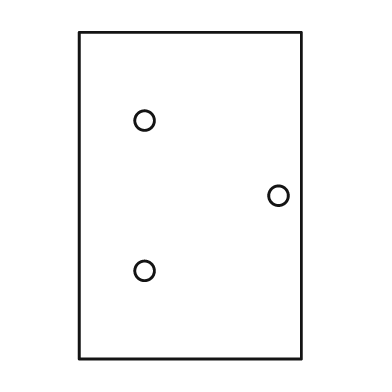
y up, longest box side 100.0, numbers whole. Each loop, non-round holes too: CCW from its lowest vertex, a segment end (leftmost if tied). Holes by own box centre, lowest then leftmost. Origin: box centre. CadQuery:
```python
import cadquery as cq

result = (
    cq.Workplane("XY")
    .moveTo(-34.0, -50.0)
    .lineTo(34.0, -50.0)
    .lineTo(34.0, 50.0)
    .lineTo(-34.0, 50.0)
    .close()
    .moveTo(-14.0, -23.0)
    .circle(3.0)
    .moveTo(27.0, 0.0)
    .circle(3.0)
    .moveTo(-14.0, 23.0)
    .circle(3.0)
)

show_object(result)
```